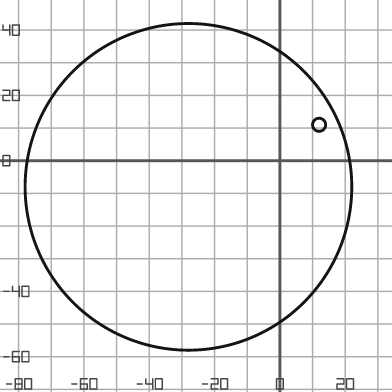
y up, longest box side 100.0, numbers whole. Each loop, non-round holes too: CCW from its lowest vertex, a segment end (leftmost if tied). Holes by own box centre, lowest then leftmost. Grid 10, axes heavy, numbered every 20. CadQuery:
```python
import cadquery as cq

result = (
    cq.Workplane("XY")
    .moveTo(-28.0, -8.0)
    .circle(50.0)
    .moveTo(12.0, 11.0)
    .circle(2.0)
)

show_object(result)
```